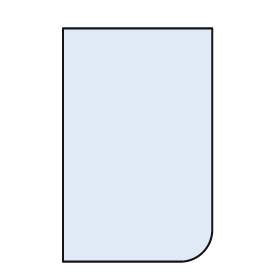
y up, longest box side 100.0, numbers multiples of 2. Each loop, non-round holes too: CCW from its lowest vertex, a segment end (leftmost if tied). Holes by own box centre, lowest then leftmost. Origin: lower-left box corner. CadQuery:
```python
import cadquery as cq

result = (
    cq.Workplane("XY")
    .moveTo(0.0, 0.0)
    .lineTo(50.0, 0.0)
    .threePointArc((60.0, 4.0), (64.0, 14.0))
    .lineTo(64.0, 100.0)
    .lineTo(0.0, 100.0)
    .close()
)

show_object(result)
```